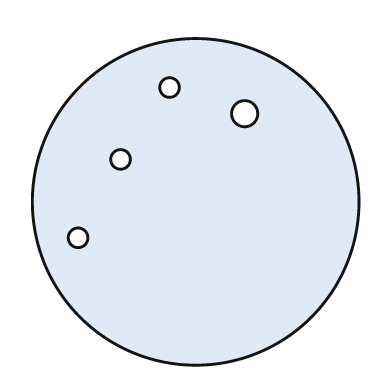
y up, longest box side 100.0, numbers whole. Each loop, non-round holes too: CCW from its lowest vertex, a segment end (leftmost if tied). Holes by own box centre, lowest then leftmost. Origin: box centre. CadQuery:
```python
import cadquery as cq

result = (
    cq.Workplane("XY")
    .moveTo(0.0, 0.0)
    .circle(50.0)
    .moveTo(-36.0, -11.0)
    .circle(3.0)
    .moveTo(-23.0, 13.0)
    .circle(3.0)
    .moveTo(15.0, 27.0)
    .circle(4.0)
    .moveTo(-8.0, 35.0)
    .circle(3.0)
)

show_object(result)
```